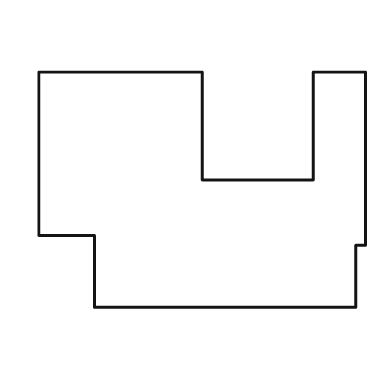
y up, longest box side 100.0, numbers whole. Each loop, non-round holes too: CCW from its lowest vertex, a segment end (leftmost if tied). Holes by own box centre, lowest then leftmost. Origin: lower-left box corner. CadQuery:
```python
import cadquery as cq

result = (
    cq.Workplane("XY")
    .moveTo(17.0, 0.0)
    .lineTo(97.0, 0.0)
    .lineTo(97.0, 19.0)
    .lineTo(100.0, 19.0)
    .lineTo(100.0, 72.0)
    .lineTo(84.0, 72.0)
    .lineTo(84.0, 39.0)
    .lineTo(50.0, 39.0)
    .lineTo(50.0, 72.0)
    .lineTo(0.0, 72.0)
    .lineTo(0.0, 22.0)
    .lineTo(17.0, 22.0)
    .close()
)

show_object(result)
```